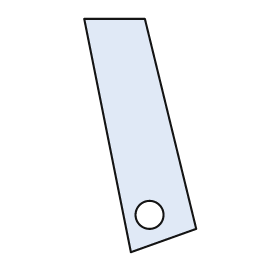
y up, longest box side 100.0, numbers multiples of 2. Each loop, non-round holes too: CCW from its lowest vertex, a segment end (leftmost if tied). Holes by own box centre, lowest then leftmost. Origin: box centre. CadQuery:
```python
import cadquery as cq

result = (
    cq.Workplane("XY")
    .moveTo(-4.0, -50.0)
    .lineTo(24.0, -40.0)
    .lineTo(2.0, 50.0)
    .lineTo(-24.0, 50.0)
    .close()
    .moveTo(4.0, -34.0)
    .circle(6.0)
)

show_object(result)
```